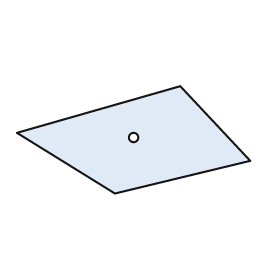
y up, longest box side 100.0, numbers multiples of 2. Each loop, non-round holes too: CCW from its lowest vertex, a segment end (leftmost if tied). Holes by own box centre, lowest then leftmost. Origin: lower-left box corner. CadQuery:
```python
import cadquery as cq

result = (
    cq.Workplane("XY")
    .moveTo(42.0, 0.0)
    .lineTo(100.0, 14.0)
    .lineTo(70.0, 46.0)
    .lineTo(0.0, 26.0)
    .close()
    .moveTo(50.0, 24.0)
    .circle(2.0)
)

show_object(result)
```